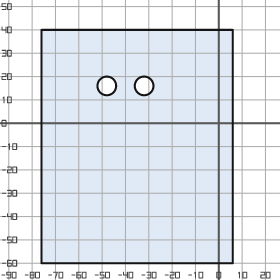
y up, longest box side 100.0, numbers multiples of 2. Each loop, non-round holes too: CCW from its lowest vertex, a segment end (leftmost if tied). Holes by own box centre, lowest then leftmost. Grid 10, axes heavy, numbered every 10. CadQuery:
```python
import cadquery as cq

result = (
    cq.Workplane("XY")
    .moveTo(-76.0, -60.0)
    .lineTo(6.0, -60.0)
    .lineTo(6.0, 40.0)
    .lineTo(-76.0, 40.0)
    .close()
    .moveTo(-48.0, 16.0)
    .circle(4.0)
    .moveTo(-32.0, 16.0)
    .circle(4.0)
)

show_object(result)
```